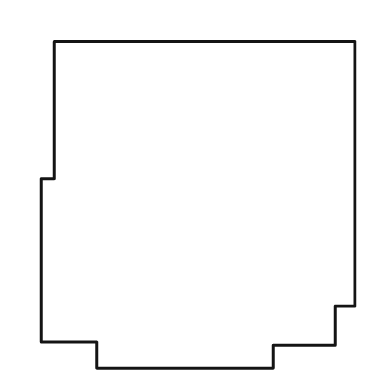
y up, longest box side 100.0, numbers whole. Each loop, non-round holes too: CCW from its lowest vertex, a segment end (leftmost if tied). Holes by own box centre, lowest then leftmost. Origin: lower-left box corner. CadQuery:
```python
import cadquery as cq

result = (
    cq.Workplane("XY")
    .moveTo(17.0, 0.0)
    .lineTo(71.0, 0.0)
    .lineTo(71.0, 7.0)
    .lineTo(90.0, 7.0)
    .lineTo(90.0, 19.0)
    .lineTo(96.0, 19.0)
    .lineTo(96.0, 100.0)
    .lineTo(4.0, 100.0)
    .lineTo(4.0, 58.0)
    .lineTo(0.0, 58.0)
    .lineTo(0.0, 8.0)
    .lineTo(17.0, 8.0)
    .close()
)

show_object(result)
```